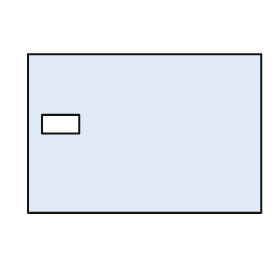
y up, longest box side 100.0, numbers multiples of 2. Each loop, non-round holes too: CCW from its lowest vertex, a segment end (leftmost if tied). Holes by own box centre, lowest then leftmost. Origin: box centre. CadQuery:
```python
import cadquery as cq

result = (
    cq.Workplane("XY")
    .moveTo(-50.0, -34.0)
    .lineTo(50.0, -34.0)
    .lineTo(50.0, 34.0)
    .lineTo(-50.0, 34.0)
    .close()
    .moveTo(-44.0, 0.0)
    .lineTo(-28.0, 0.0)
    .lineTo(-28.0, 8.0)
    .lineTo(-44.0, 8.0)
    .close()
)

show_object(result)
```